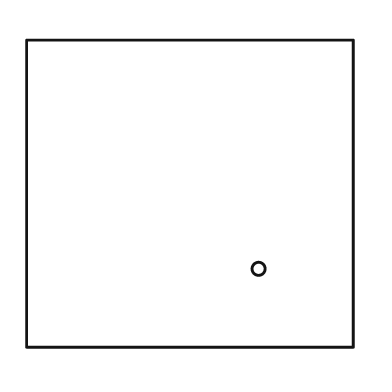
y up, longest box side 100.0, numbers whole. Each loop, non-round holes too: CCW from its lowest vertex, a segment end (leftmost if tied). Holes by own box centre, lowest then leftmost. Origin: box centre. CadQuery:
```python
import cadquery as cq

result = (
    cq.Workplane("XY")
    .moveTo(-50.0, -47.0)
    .lineTo(50.0, -47.0)
    .lineTo(50.0, 47.0)
    .lineTo(-50.0, 47.0)
    .close()
    .moveTo(21.0, -23.0)
    .circle(2.0)
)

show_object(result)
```